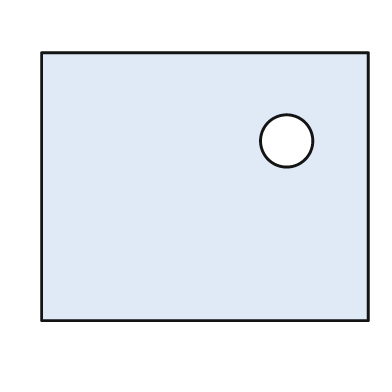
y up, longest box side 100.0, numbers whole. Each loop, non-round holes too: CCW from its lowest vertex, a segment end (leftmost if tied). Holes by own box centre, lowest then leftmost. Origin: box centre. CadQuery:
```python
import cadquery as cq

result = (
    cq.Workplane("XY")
    .moveTo(-50.0, -41.0)
    .lineTo(50.0, -41.0)
    .lineTo(50.0, 41.0)
    .lineTo(-50.0, 41.0)
    .close()
    .moveTo(25.0, 14.0)
    .circle(8.0)
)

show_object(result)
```